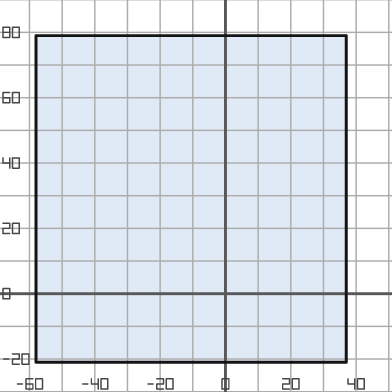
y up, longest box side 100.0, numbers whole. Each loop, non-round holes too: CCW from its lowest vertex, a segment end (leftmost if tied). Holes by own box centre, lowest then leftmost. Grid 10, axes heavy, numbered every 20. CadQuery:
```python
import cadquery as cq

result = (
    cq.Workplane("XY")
    .moveTo(-58.0, -21.0)
    .lineTo(37.0, -21.0)
    .lineTo(37.0, 79.0)
    .lineTo(-58.0, 79.0)
    .close()
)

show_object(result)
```